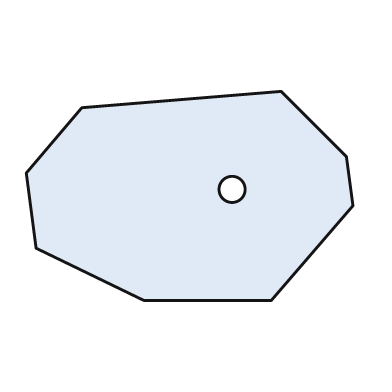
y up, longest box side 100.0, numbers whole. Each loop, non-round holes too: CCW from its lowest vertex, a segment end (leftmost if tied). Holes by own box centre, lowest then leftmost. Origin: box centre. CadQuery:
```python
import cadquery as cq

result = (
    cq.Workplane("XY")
    .moveTo(-14.0, -32.0)
    .lineTo(25.0, -32.0)
    .lineTo(50.0, -3.0)
    .lineTo(48.0, 12.0)
    .lineTo(28.0, 32.0)
    .lineTo(-33.0, 27.0)
    .lineTo(-50.0, 7.0)
    .lineTo(-47.0, -16.0)
    .close()
    .moveTo(13.0, 2.0)
    .circle(4.0)
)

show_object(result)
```